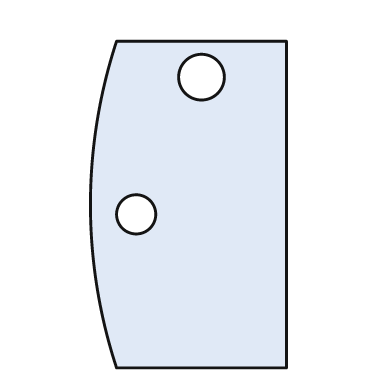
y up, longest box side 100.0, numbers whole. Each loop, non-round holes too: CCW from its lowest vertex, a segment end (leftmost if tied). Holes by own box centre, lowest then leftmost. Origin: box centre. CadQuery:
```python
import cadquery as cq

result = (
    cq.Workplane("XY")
    .moveTo(-22.0, -50.0)
    .lineTo(30.0, -50.0)
    .lineTo(30.0, 50.0)
    .lineTo(-22.0, 50.0)
    .threePointArc((-30.0, 0.0), (-22.0, -50.0))
    .close()
    .moveTo(-16.0, -3.0)
    .circle(6.0)
    .moveTo(4.0, 39.0)
    .circle(7.0)
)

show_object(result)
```